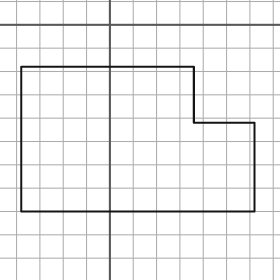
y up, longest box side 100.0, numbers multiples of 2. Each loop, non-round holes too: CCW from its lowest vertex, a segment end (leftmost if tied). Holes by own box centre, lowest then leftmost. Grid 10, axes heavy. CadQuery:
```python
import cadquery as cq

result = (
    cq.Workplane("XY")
    .moveTo(-38.0, -80.0)
    .lineTo(62.0, -80.0)
    .lineTo(62.0, -42.0)
    .lineTo(36.0, -42.0)
    .lineTo(36.0, -18.0)
    .lineTo(-38.0, -18.0)
    .close()
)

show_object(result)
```